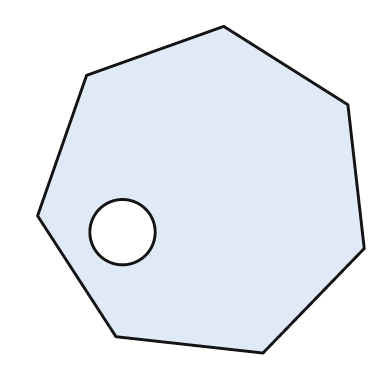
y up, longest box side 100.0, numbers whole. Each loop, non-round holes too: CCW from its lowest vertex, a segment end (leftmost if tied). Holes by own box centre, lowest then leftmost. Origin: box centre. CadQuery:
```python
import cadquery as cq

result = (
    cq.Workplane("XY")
    .moveTo(19.0, -50.0)
    .lineTo(50.0, -18.0)
    .lineTo(45.0, 26.0)
    .lineTo(7.0, 50.0)
    .lineTo(-35.0, 35.0)
    .lineTo(-50.0, -8.0)
    .lineTo(-26.0, -45.0)
    .close()
    .moveTo(-24.0, -13.0)
    .circle(10.0)
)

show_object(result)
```